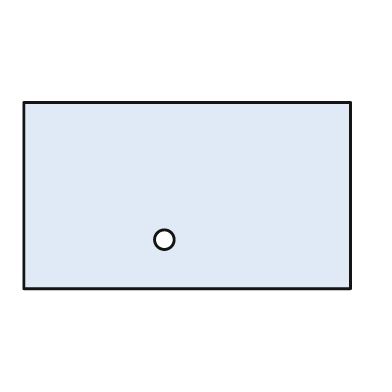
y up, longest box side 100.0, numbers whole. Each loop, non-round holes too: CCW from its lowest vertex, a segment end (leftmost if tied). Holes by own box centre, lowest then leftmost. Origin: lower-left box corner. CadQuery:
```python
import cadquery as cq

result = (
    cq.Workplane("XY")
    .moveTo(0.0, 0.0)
    .lineTo(100.0, 0.0)
    .lineTo(100.0, 57.0)
    .lineTo(0.0, 57.0)
    .close()
    .moveTo(43.0, 15.0)
    .circle(3.0)
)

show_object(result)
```